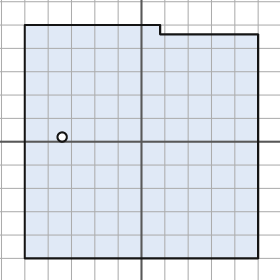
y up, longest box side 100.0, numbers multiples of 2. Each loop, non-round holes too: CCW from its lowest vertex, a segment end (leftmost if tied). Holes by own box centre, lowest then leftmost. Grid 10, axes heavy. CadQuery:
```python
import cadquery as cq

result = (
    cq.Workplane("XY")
    .moveTo(-50.0, -50.0)
    .lineTo(50.0, -50.0)
    .lineTo(50.0, 46.0)
    .lineTo(8.0, 46.0)
    .lineTo(8.0, 50.0)
    .lineTo(-50.0, 50.0)
    .close()
    .moveTo(-34.0, 2.0)
    .circle(2.0)
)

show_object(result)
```